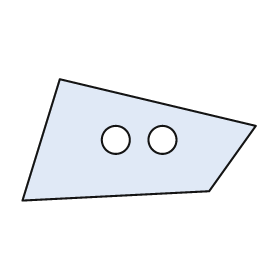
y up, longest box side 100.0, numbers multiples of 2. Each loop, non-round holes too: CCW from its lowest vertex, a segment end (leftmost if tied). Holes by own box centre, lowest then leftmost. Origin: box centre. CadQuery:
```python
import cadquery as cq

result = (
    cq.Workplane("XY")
    .moveTo(-50.0, -26.0)
    .lineTo(30.0, -22.0)
    .lineTo(50.0, 6.0)
    .lineTo(-34.0, 26.0)
    .close()
    .moveTo(-10.0, 0.0)
    .circle(6.0)
    .moveTo(10.0, 0.0)
    .circle(6.0)
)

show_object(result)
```